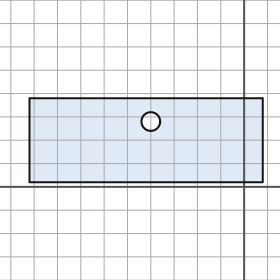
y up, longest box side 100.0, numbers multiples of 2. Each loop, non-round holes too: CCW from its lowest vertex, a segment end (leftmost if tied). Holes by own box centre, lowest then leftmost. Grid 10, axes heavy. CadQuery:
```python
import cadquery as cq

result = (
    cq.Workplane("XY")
    .moveTo(-92.0, 2.0)
    .lineTo(8.0, 2.0)
    .lineTo(8.0, 38.0)
    .lineTo(-92.0, 38.0)
    .close()
    .moveTo(-40.0, 28.0)
    .circle(4.0)
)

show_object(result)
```